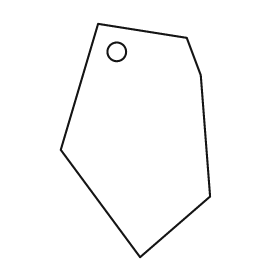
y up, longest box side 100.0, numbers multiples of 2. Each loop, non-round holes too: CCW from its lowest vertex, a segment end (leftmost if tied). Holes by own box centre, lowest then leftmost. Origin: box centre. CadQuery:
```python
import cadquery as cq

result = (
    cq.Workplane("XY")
    .moveTo(2.0, -50.0)
    .lineTo(32.0, -24.0)
    .lineTo(28.0, 28.0)
    .lineTo(22.0, 44.0)
    .lineTo(-16.0, 50.0)
    .lineTo(-32.0, -4.0)
    .close()
    .moveTo(-8.0, 38.0)
    .circle(4.0)
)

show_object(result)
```